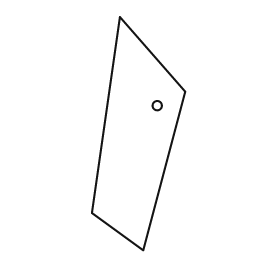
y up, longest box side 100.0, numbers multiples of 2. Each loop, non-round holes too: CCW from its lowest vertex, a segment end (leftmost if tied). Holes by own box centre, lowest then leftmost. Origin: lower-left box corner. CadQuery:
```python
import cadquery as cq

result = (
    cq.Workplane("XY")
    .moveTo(22.0, 0.0)
    .lineTo(40.0, 68.0)
    .lineTo(12.0, 100.0)
    .lineTo(0.0, 16.0)
    .close()
    .moveTo(28.0, 62.0)
    .circle(2.0)
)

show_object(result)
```